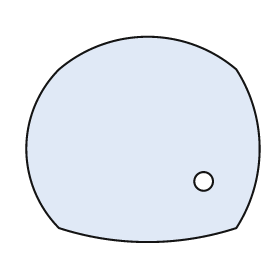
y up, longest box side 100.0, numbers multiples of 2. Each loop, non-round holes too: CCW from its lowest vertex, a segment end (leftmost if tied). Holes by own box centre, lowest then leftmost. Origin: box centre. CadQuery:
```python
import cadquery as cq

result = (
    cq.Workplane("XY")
    .moveTo(-36.0, -38.0)
    .threePointArc((2.0, -44.0), (40.0, -38.0))
    .threePointArc((50.0, -4.0), (40.0, 30.0))
    .threePointArc((2.0, 44.0), (-36.0, 30.0))
    .threePointArc((-50.0, -4.0), (-36.0, -38.0))
    .close()
    .moveTo(26.0, -18.0)
    .circle(4.0)
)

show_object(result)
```